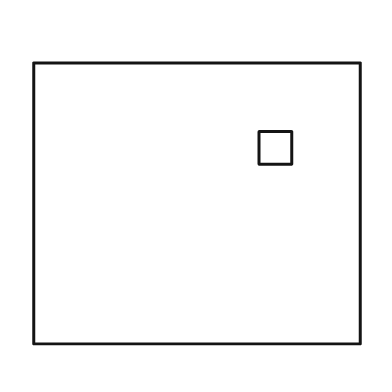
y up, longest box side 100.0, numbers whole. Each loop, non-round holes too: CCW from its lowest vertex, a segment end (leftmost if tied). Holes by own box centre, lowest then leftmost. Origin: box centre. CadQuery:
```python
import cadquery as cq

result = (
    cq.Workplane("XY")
    .moveTo(-50.0, -43.0)
    .lineTo(50.0, -43.0)
    .lineTo(50.0, 43.0)
    .lineTo(-50.0, 43.0)
    .close()
    .moveTo(19.0, 12.0)
    .lineTo(29.0, 12.0)
    .lineTo(29.0, 22.0)
    .lineTo(19.0, 22.0)
    .close()
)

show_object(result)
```